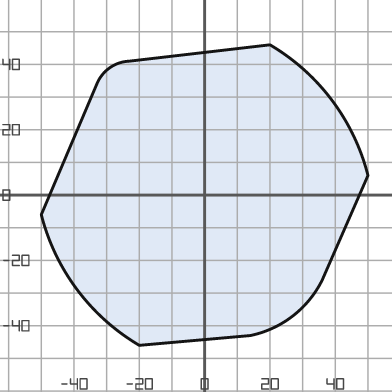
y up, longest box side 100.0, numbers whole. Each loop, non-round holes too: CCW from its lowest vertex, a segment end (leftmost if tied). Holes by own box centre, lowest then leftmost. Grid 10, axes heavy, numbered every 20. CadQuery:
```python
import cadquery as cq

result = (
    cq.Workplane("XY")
    .moveTo(-20.0, -46.0)
    .lineTo(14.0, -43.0)
    .threePointArc((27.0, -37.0), (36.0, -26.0))
    .lineTo(50.0, 6.0)
    .threePointArc((39.0, 29.0), (20.0, 46.0))
    .lineTo(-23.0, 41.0)
    .threePointArc((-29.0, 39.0), (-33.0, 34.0))
    .lineTo(-50.0, -6.0)
    .threePointArc((-39.0, -29.0), (-20.0, -46.0))
    .close()
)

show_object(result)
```